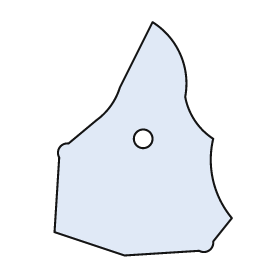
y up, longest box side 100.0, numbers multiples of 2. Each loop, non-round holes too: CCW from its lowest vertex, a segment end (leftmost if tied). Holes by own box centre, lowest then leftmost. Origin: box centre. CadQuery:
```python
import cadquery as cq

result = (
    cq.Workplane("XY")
    .moveTo(-8.0, -50.0)
    .lineTo(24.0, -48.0)
    .threePointArc((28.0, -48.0), (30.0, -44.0))
    .lineTo(38.0, -34.0)
    .threePointArc((30.0, -18.0), (30.0, 0.0))
    .threePointArc((22.0, 8.0), (18.0, 18.0))
    .threePointArc((16.0, 36.0), (4.0, 50.0))
    .lineTo(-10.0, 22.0)
    .threePointArc((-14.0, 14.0), (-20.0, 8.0))
    .lineTo(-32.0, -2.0)
    .threePointArc((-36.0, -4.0), (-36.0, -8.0))
    .lineTo(-38.0, -40.0)
    .close()
    .moveTo(0.0, 0.0)
    .circle(4.0)
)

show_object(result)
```